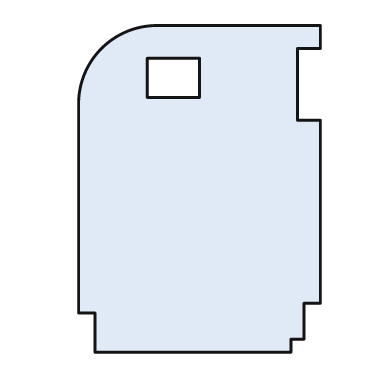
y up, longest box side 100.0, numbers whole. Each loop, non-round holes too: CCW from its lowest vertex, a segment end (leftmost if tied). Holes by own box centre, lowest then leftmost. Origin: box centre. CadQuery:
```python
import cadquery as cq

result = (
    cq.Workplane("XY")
    .moveTo(-32.0, -50.0)
    .lineTo(28.0, -50.0)
    .lineTo(28.0, -46.0)
    .lineTo(32.0, -46.0)
    .lineTo(32.0, -35.0)
    .lineTo(37.0, -35.0)
    .lineTo(37.0, 21.0)
    .lineTo(30.0, 21.0)
    .lineTo(30.0, 43.0)
    .lineTo(37.0, 43.0)
    .lineTo(37.0, 50.0)
    .lineTo(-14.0, 50.0)
    .threePointArc((-30.0, 43.0), (-37.0, 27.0))
    .lineTo(-37.0, -38.0)
    .lineTo(-32.0, -38.0)
    .close()
    .moveTo(-16.0, 28.0)
    .lineTo(0.0, 28.0)
    .lineTo(0.0, 40.0)
    .lineTo(-16.0, 40.0)
    .close()
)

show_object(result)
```